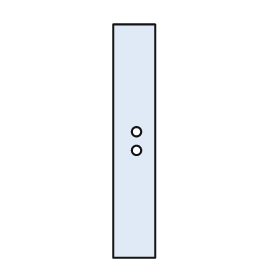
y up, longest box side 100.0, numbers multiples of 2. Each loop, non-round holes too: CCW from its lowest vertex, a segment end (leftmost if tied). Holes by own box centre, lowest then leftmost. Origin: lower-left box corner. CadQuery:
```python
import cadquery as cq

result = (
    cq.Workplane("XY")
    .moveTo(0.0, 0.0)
    .lineTo(18.0, 0.0)
    .lineTo(18.0, 100.0)
    .lineTo(0.0, 100.0)
    .close()
    .moveTo(10.0, 46.0)
    .circle(2.0)
    .moveTo(10.0, 54.0)
    .circle(2.0)
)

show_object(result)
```